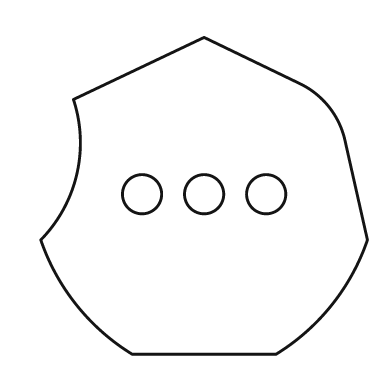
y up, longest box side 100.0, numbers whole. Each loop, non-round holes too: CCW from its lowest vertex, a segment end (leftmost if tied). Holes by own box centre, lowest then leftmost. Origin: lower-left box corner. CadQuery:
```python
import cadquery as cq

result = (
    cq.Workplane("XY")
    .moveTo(28.0, 0.0)
    .lineTo(72.0, 0.0)
    .threePointArc((89.0, 15.0), (100.0, 35.0))
    .lineTo(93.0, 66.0)
    .threePointArc((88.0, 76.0), (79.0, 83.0))
    .lineTo(50.0, 97.0)
    .lineTo(10.0, 78.0)
    .threePointArc((11.0, 55.0), (0.0, 35.0))
    .threePointArc((11.0, 15.0), (28.0, 0.0))
    .close()
    .moveTo(31.0, 49.0)
    .circle(6.0)
    .moveTo(50.0, 49.0)
    .circle(6.0)
    .moveTo(69.0, 49.0)
    .circle(6.0)
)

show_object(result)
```